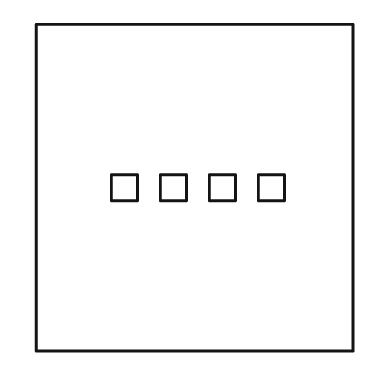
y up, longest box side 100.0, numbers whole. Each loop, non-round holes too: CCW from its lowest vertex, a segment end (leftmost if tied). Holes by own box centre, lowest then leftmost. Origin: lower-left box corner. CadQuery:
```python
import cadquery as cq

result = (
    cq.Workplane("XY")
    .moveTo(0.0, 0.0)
    .lineTo(97.0, 0.0)
    .lineTo(97.0, 100.0)
    .lineTo(0.0, 100.0)
    .close()
    .moveTo(23.0, 46.0)
    .lineTo(31.0, 46.0)
    .lineTo(31.0, 54.0)
    .lineTo(23.0, 54.0)
    .close()
    .moveTo(38.0, 46.0)
    .lineTo(46.0, 46.0)
    .lineTo(46.0, 54.0)
    .lineTo(38.0, 54.0)
    .close()
    .moveTo(53.0, 46.0)
    .lineTo(61.0, 46.0)
    .lineTo(61.0, 54.0)
    .lineTo(53.0, 54.0)
    .close()
    .moveTo(68.0, 46.0)
    .lineTo(76.0, 46.0)
    .lineTo(76.0, 54.0)
    .lineTo(68.0, 54.0)
    .close()
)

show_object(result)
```